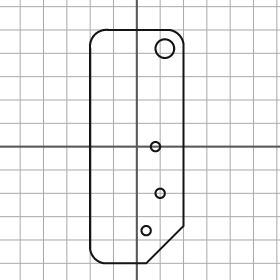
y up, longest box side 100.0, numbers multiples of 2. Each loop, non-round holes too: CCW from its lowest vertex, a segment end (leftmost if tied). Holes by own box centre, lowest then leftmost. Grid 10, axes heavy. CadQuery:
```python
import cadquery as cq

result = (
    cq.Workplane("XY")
    .moveTo(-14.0, -50.0)
    .lineTo(4.0, -50.0)
    .lineTo(20.0, -34.0)
    .lineTo(20.0, 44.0)
    .threePointArc((18.0, 48.0), (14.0, 50.0))
    .lineTo(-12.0, 50.0)
    .threePointArc((-18.0, 48.0), (-20.0, 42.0))
    .lineTo(-20.0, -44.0)
    .threePointArc((-18.0, -48.0), (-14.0, -50.0))
    .close()
    .moveTo(4.0, -36.0)
    .circle(2.0)
    .moveTo(10.0, -20.0)
    .circle(2.0)
    .moveTo(8.0, 0.0)
    .circle(2.0)
    .moveTo(12.0, 42.0)
    .circle(4.0)
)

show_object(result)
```